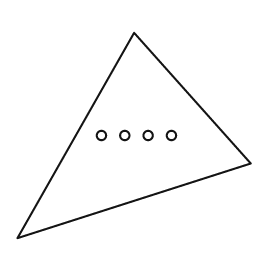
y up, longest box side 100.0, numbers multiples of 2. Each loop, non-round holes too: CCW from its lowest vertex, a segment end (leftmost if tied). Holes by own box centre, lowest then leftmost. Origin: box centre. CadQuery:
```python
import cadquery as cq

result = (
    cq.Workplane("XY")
    .moveTo(-50.0, -44.0)
    .lineTo(50.0, -12.0)
    .lineTo(0.0, 44.0)
    .close()
    .moveTo(-14.0, 0.0)
    .circle(2.0)
    .moveTo(-4.0, 0.0)
    .circle(2.0)
    .moveTo(6.0, 0.0)
    .circle(2.0)
    .moveTo(16.0, 0.0)
    .circle(2.0)
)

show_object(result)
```